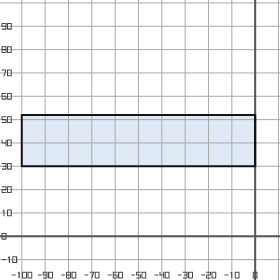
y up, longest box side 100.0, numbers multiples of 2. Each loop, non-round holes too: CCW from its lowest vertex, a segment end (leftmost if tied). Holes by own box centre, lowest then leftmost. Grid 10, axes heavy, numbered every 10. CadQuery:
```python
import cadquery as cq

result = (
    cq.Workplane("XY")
    .moveTo(-100.0, 30.0)
    .lineTo(0.0, 30.0)
    .lineTo(0.0, 52.0)
    .lineTo(-100.0, 52.0)
    .close()
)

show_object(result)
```